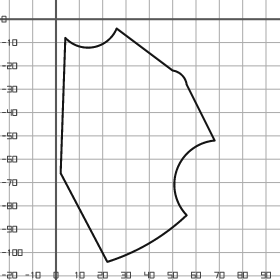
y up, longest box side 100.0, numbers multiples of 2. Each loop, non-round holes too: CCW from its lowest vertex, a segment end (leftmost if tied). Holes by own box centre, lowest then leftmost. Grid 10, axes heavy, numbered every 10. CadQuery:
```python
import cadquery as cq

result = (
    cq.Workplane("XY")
    .moveTo(22.0, -104.0)
    .threePointArc((40.0, -96.0), (56.0, -84.0))
    .threePointArc((52.0, -64.0), (68.0, -52.0))
    .lineTo(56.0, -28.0)
    .threePointArc((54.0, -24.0), (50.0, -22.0))
    .lineTo(26.0, -4.0)
    .threePointArc((16.0, -12.0), (4.0, -8.0))
    .lineTo(2.0, -66.0)
    .close()
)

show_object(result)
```